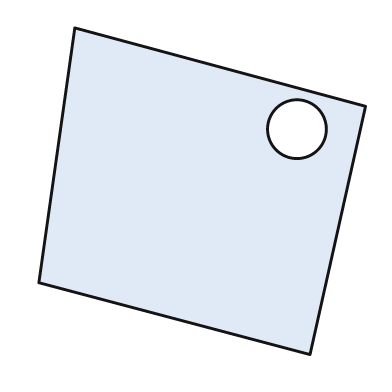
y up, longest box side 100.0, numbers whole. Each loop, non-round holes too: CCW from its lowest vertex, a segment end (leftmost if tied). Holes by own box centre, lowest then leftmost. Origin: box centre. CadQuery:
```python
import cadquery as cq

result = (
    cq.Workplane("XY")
    .moveTo(33.0, -50.0)
    .lineTo(50.0, 26.0)
    .lineTo(-39.0, 50.0)
    .lineTo(-50.0, -28.0)
    .close()
    .moveTo(29.0, 19.0)
    .circle(9.0)
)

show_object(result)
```